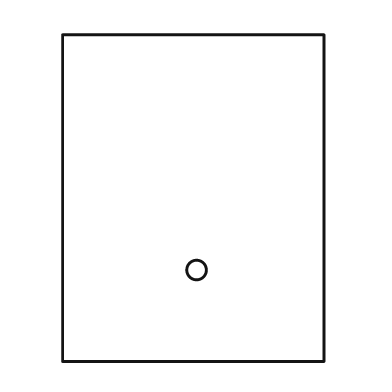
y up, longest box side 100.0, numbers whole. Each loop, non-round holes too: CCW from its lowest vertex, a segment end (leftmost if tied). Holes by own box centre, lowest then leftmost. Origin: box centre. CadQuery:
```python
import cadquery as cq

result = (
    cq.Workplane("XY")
    .moveTo(-40.0, -50.0)
    .lineTo(40.0, -50.0)
    .lineTo(40.0, 50.0)
    .lineTo(-40.0, 50.0)
    .close()
    .moveTo(1.0, -22.0)
    .circle(3.0)
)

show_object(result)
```